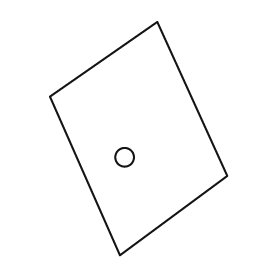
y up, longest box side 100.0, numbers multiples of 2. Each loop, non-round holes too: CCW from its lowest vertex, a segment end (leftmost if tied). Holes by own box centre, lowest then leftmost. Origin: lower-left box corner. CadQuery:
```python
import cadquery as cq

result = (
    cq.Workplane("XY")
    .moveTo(30.0, 0.0)
    .lineTo(76.0, 34.0)
    .lineTo(46.0, 100.0)
    .lineTo(0.0, 68.0)
    .close()
    .moveTo(32.0, 42.0)
    .circle(4.0)
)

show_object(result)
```